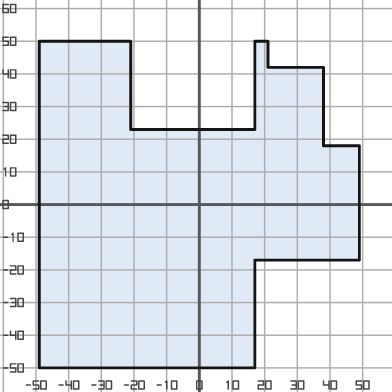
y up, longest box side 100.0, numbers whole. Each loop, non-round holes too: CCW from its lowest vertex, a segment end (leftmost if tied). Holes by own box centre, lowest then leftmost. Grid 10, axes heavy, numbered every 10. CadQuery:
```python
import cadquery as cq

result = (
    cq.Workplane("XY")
    .moveTo(-49.0, -50.0)
    .lineTo(17.0, -50.0)
    .lineTo(17.0, -17.0)
    .lineTo(49.0, -17.0)
    .lineTo(49.0, 18.0)
    .lineTo(38.0, 18.0)
    .lineTo(38.0, 42.0)
    .lineTo(21.0, 42.0)
    .lineTo(21.0, 50.0)
    .lineTo(17.0, 50.0)
    .lineTo(17.0, 23.0)
    .lineTo(-21.0, 23.0)
    .lineTo(-21.0, 50.0)
    .lineTo(-49.0, 50.0)
    .close()
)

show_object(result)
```